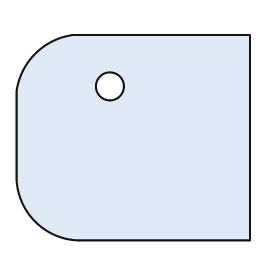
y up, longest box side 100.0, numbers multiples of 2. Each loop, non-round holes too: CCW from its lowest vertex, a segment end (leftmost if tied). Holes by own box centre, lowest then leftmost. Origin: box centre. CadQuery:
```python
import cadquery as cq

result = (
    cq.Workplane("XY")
    .moveTo(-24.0, -44.0)
    .lineTo(50.0, -44.0)
    .lineTo(50.0, 44.0)
    .lineTo(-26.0, 44.0)
    .threePointArc((-42.0, 36.0), (-50.0, 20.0))
    .lineTo(-50.0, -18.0)
    .threePointArc((-42.0, -36.0), (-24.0, -44.0))
    .close()
    .moveTo(-10.0, 22.0)
    .circle(6.0)
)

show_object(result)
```